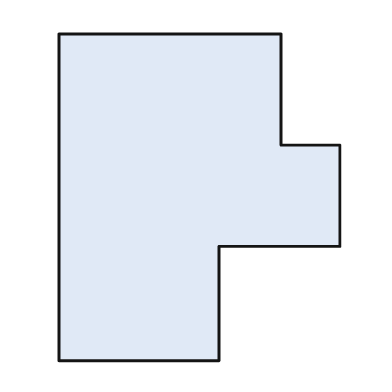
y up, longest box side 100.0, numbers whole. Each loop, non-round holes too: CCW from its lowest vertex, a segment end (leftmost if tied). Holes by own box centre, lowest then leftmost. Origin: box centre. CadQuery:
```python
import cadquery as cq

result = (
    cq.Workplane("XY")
    .moveTo(-43.0, -50.0)
    .lineTo(6.0, -50.0)
    .lineTo(6.0, -15.0)
    .lineTo(43.0, -15.0)
    .lineTo(43.0, 16.0)
    .lineTo(25.0, 16.0)
    .lineTo(25.0, 50.0)
    .lineTo(-43.0, 50.0)
    .close()
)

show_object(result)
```